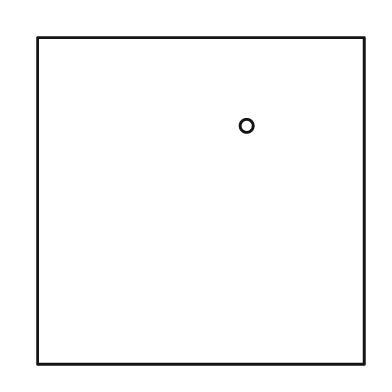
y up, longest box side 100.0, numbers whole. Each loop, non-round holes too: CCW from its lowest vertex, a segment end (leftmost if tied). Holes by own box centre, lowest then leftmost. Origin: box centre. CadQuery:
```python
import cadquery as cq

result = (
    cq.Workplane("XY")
    .moveTo(-50.0, -50.0)
    .lineTo(50.0, -50.0)
    .lineTo(50.0, 50.0)
    .lineTo(-50.0, 50.0)
    .close()
    .moveTo(14.0, 23.0)
    .circle(2.0)
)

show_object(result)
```